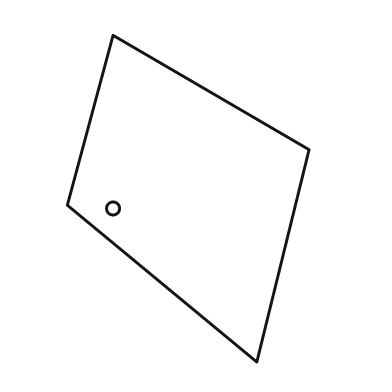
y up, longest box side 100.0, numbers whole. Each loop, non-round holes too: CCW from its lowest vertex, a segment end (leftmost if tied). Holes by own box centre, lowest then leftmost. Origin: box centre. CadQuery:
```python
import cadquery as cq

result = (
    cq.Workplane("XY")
    .moveTo(21.0, -50.0)
    .lineTo(37.0, 15.0)
    .lineTo(-23.0, 50.0)
    .lineTo(-37.0, -2.0)
    .close()
    .moveTo(-23.0, -3.0)
    .circle(2.0)
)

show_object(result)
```